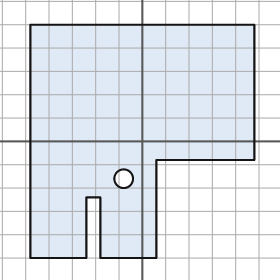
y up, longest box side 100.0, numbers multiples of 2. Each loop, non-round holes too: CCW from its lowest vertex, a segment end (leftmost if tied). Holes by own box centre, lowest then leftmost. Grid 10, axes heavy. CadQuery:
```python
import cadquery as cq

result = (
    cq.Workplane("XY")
    .moveTo(-48.0, -50.0)
    .lineTo(-24.0, -50.0)
    .lineTo(-24.0, -24.0)
    .lineTo(-18.0, -24.0)
    .lineTo(-18.0, -50.0)
    .lineTo(6.0, -50.0)
    .lineTo(6.0, -8.0)
    .lineTo(48.0, -8.0)
    .lineTo(48.0, 50.0)
    .lineTo(-48.0, 50.0)
    .close()
    .moveTo(-8.0, -16.0)
    .circle(4.0)
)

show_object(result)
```